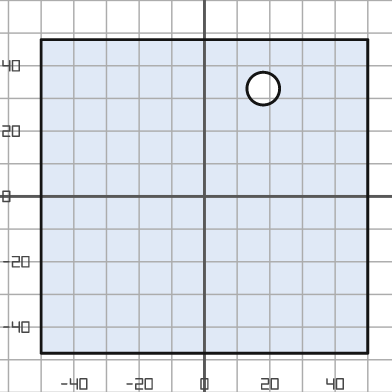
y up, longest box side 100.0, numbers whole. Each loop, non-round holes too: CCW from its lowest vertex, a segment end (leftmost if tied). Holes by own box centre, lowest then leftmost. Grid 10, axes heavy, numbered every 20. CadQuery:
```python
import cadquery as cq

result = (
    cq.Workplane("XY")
    .moveTo(-50.0, -48.0)
    .lineTo(50.0, -48.0)
    .lineTo(50.0, 48.0)
    .lineTo(-50.0, 48.0)
    .close()
    .moveTo(18.0, 33.0)
    .circle(5.0)
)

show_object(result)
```